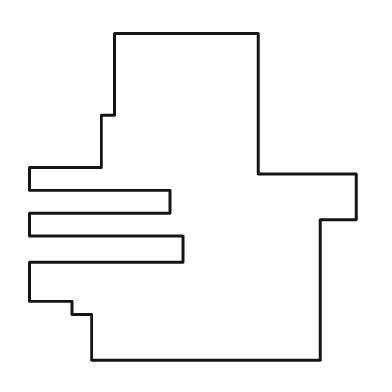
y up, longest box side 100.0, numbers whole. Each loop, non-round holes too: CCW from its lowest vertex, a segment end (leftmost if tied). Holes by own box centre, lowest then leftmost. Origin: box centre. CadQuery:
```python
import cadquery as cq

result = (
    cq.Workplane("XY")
    .moveTo(-31.0, -50.0)
    .lineTo(39.0, -50.0)
    .lineTo(39.0, -7.0)
    .lineTo(50.0, -7.0)
    .lineTo(50.0, 7.0)
    .lineTo(20.0, 7.0)
    .lineTo(20.0, 50.0)
    .lineTo(-24.0, 50.0)
    .lineTo(-24.0, 25.0)
    .lineTo(-28.0, 25.0)
    .lineTo(-28.0, 9.0)
    .lineTo(-50.0, 9.0)
    .lineTo(-50.0, 2.0)
    .lineTo(-7.0, 2.0)
    .lineTo(-7.0, -5.0)
    .lineTo(-50.0, -5.0)
    .lineTo(-50.0, -12.0)
    .lineTo(-3.0, -12.0)
    .lineTo(-3.0, -20.0)
    .lineTo(-50.0, -20.0)
    .lineTo(-50.0, -32.0)
    .lineTo(-37.0, -32.0)
    .lineTo(-37.0, -36.0)
    .lineTo(-31.0, -36.0)
    .close()
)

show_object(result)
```